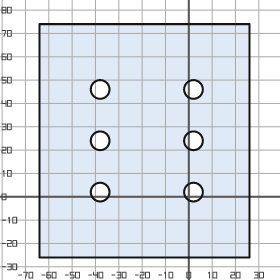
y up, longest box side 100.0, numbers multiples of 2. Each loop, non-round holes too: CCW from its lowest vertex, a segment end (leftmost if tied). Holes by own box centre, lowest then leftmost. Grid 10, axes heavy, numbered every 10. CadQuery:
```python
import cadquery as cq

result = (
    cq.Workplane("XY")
    .moveTo(-64.0, -26.0)
    .lineTo(26.0, -26.0)
    .lineTo(26.0, 74.0)
    .lineTo(-64.0, 74.0)
    .close()
    .moveTo(-38.0, 2.0)
    .circle(4.0)
    .moveTo(2.0, 2.0)
    .circle(4.0)
    .moveTo(-38.0, 24.0)
    .circle(4.0)
    .moveTo(2.0, 24.0)
    .circle(4.0)
    .moveTo(-38.0, 46.0)
    .circle(4.0)
    .moveTo(2.0, 46.0)
    .circle(4.0)
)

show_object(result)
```